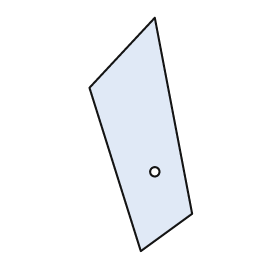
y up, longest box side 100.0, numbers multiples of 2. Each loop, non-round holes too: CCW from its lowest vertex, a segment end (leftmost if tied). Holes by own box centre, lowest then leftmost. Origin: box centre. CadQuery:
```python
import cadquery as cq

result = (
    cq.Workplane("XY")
    .moveTo(0.0, -50.0)
    .lineTo(22.0, -34.0)
    .lineTo(6.0, 50.0)
    .lineTo(-22.0, 20.0)
    .close()
    .moveTo(6.0, -16.0)
    .circle(2.0)
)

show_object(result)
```